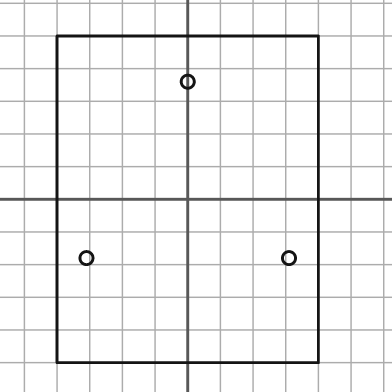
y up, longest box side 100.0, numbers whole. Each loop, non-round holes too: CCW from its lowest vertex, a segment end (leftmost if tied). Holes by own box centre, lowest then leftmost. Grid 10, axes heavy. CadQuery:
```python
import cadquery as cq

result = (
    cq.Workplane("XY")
    .moveTo(-40.0, -50.0)
    .lineTo(40.0, -50.0)
    .lineTo(40.0, 50.0)
    .lineTo(-40.0, 50.0)
    .close()
    .moveTo(-31.0, -18.0)
    .circle(2.0)
    .moveTo(31.0, -18.0)
    .circle(2.0)
    .moveTo(0.0, 36.0)
    .circle(2.0)
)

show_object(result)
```